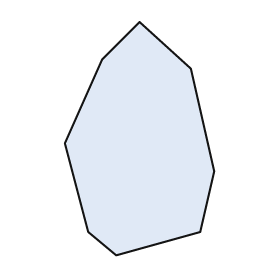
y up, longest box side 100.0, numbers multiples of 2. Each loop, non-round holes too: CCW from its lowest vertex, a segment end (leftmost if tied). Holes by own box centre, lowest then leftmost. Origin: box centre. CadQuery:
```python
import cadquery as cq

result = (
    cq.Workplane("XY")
    .moveTo(-10.0, -50.0)
    .lineTo(26.0, -40.0)
    .lineTo(32.0, -14.0)
    .lineTo(22.0, 30.0)
    .lineTo(0.0, 50.0)
    .lineTo(-16.0, 34.0)
    .lineTo(-32.0, -2.0)
    .lineTo(-22.0, -40.0)
    .close()
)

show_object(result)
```